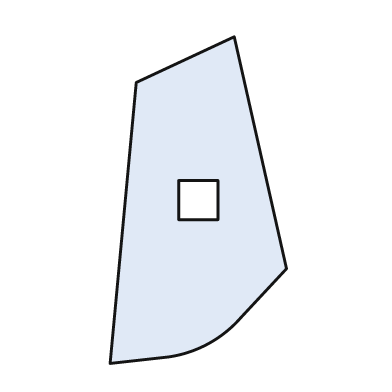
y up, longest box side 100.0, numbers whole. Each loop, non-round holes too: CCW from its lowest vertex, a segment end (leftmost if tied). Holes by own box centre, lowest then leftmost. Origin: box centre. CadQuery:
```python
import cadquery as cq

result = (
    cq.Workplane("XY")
    .moveTo(-27.0, -50.0)
    .lineTo(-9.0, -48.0)
    .threePointArc((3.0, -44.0), (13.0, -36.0))
    .lineTo(27.0, -21.0)
    .lineTo(11.0, 50.0)
    .lineTo(-19.0, 36.0)
    .close()
    .moveTo(-6.0, -6.0)
    .lineTo(6.0, -6.0)
    .lineTo(6.0, 6.0)
    .lineTo(-6.0, 6.0)
    .close()
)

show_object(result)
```